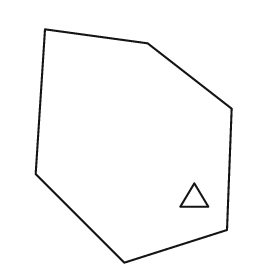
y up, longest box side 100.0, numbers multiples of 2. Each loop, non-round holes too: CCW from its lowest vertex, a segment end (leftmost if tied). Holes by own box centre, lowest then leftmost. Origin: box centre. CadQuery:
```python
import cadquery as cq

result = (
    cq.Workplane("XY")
    .moveTo(-4.0, -50.0)
    .lineTo(40.0, -36.0)
    .lineTo(42.0, 16.0)
    .lineTo(6.0, 44.0)
    .lineTo(-38.0, 50.0)
    .lineTo(-42.0, -12.0)
    .close()
    .moveTo(20.0, -26.0)
    .lineTo(32.0, -26.0)
    .lineTo(26.0, -16.0)
    .close()
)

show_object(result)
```